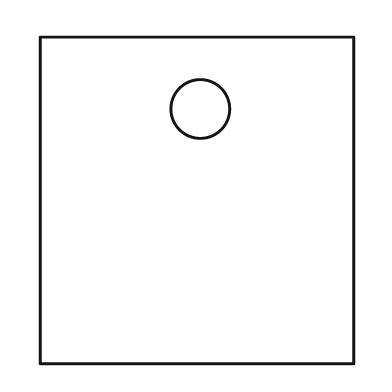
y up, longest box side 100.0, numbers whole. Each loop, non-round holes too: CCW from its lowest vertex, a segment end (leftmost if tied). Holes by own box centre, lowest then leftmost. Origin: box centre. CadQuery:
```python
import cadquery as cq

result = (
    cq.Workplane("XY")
    .moveTo(-48.0, -50.0)
    .lineTo(48.0, -50.0)
    .lineTo(48.0, 50.0)
    .lineTo(-48.0, 50.0)
    .close()
    .moveTo(1.0, 28.0)
    .circle(9.0)
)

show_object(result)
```